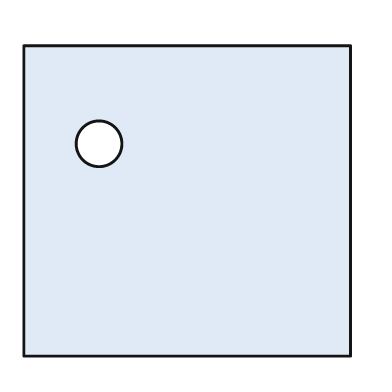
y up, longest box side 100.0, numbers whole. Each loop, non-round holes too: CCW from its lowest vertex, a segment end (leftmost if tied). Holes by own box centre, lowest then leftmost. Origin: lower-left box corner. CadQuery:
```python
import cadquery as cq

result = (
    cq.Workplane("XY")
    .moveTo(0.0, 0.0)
    .lineTo(100.0, 0.0)
    .lineTo(100.0, 95.0)
    .lineTo(0.0, 95.0)
    .close()
    .moveTo(23.0, 65.0)
    .circle(7.0)
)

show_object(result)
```